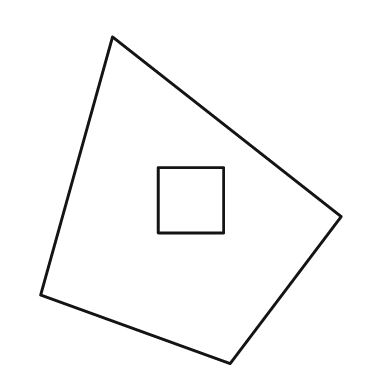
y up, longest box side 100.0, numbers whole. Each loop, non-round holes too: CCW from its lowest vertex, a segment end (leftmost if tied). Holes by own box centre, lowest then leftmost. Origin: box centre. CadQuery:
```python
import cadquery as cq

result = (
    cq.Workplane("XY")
    .moveTo(12.0, -50.0)
    .lineTo(46.0, -5.0)
    .lineTo(-24.0, 50.0)
    .lineTo(-46.0, -29.0)
    .close()
    .moveTo(-10.0, -10.0)
    .lineTo(10.0, -10.0)
    .lineTo(10.0, 10.0)
    .lineTo(-10.0, 10.0)
    .close()
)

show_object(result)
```